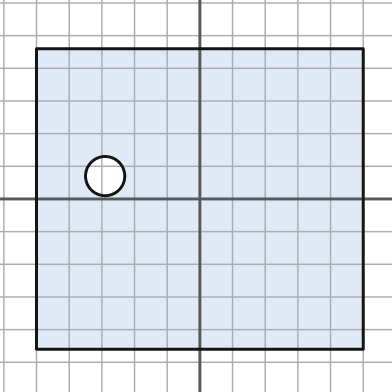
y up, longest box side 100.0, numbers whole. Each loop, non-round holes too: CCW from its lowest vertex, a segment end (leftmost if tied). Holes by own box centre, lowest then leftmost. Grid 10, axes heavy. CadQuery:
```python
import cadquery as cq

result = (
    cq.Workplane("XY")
    .moveTo(-50.0, -46.0)
    .lineTo(50.0, -46.0)
    .lineTo(50.0, 46.0)
    .lineTo(-50.0, 46.0)
    .close()
    .moveTo(-29.0, 7.0)
    .circle(6.0)
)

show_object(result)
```